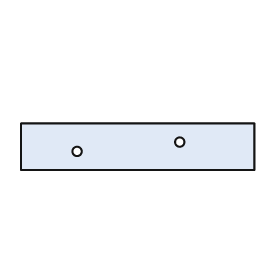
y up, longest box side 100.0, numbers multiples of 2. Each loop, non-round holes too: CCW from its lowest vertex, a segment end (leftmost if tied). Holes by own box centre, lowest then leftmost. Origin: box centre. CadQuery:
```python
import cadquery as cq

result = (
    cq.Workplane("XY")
    .moveTo(-50.0, -10.0)
    .lineTo(50.0, -10.0)
    .lineTo(50.0, 10.0)
    .lineTo(-50.0, 10.0)
    .close()
    .moveTo(-26.0, -2.0)
    .circle(2.0)
    .moveTo(18.0, 2.0)
    .circle(2.0)
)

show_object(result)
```